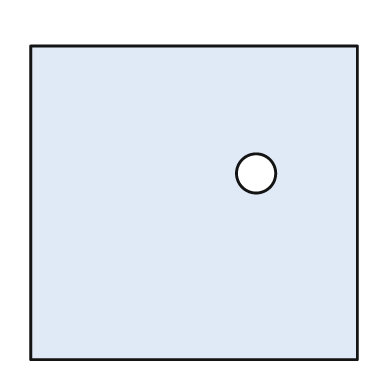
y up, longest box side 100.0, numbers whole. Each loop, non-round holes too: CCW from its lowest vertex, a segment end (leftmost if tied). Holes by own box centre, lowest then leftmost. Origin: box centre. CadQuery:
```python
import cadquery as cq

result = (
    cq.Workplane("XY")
    .moveTo(-50.0, -48.0)
    .lineTo(50.0, -48.0)
    .lineTo(50.0, 48.0)
    .lineTo(-50.0, 48.0)
    .close()
    .moveTo(19.0, 9.0)
    .circle(6.0)
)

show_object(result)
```